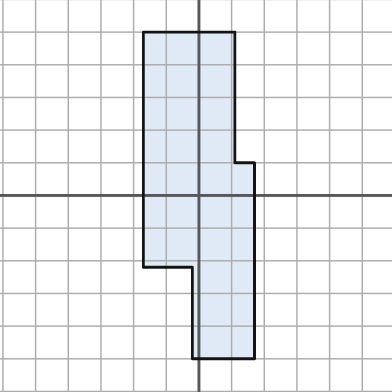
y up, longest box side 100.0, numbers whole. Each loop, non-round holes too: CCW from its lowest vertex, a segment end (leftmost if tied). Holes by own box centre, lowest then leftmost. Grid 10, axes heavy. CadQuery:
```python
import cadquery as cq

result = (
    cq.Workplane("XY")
    .moveTo(-2.0, -50.0)
    .lineTo(17.0, -50.0)
    .lineTo(17.0, 10.0)
    .lineTo(11.0, 10.0)
    .lineTo(11.0, 50.0)
    .lineTo(-17.0, 50.0)
    .lineTo(-17.0, -22.0)
    .lineTo(-2.0, -22.0)
    .close()
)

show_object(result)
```